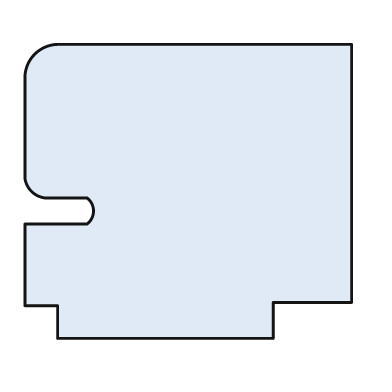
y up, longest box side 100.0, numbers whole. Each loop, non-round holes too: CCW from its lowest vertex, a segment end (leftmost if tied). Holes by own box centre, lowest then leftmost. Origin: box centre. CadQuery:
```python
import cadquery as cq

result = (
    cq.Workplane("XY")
    .moveTo(-40.0, -45.0)
    .lineTo(26.0, -45.0)
    .lineTo(26.0, -34.0)
    .lineTo(50.0, -34.0)
    .lineTo(50.0, 45.0)
    .lineTo(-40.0, 45.0)
    .threePointArc((-47.0, 42.0), (-50.0, 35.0))
    .lineTo(-50.0, 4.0)
    .threePointArc((-48.0, 0.0), (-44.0, -2.0))
    .lineTo(-31.0, -2.0)
    .threePointArc((-29.0, -6.0), (-31.0, -10.0))
    .lineTo(-50.0, -10.0)
    .lineTo(-50.0, -35.0)
    .lineTo(-40.0, -35.0)
    .close()
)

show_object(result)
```